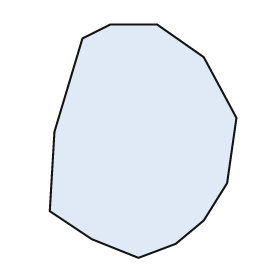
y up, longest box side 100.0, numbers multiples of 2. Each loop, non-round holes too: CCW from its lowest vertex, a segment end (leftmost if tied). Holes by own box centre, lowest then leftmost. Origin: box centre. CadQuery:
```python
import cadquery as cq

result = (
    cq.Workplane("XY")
    .moveTo(-2.0, -50.0)
    .lineTo(14.0, -44.0)
    .lineTo(26.0, -34.0)
    .lineTo(36.0, -18.0)
    .lineTo(40.0, 10.0)
    .lineTo(26.0, 36.0)
    .lineTo(6.0, 50.0)
    .lineTo(-14.0, 50.0)
    .lineTo(-26.0, 44.0)
    .lineTo(-38.0, 4.0)
    .lineTo(-40.0, -30.0)
    .lineTo(-22.0, -42.0)
    .close()
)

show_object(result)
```